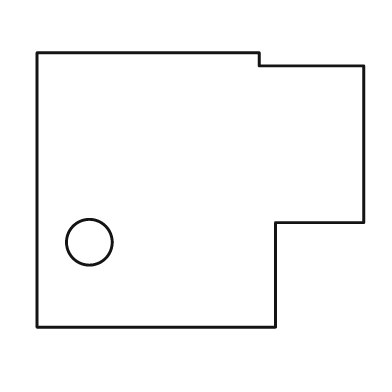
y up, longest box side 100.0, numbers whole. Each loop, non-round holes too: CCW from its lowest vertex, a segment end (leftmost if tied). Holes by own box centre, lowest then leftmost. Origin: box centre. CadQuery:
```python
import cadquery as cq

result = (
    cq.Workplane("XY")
    .moveTo(-50.0, -42.0)
    .lineTo(23.0, -42.0)
    .lineTo(23.0, -10.0)
    .lineTo(50.0, -10.0)
    .lineTo(50.0, 38.0)
    .lineTo(18.0, 38.0)
    .lineTo(18.0, 42.0)
    .lineTo(-50.0, 42.0)
    .close()
    .moveTo(-34.0, -16.0)
    .circle(7.0)
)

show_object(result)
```